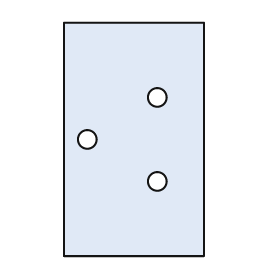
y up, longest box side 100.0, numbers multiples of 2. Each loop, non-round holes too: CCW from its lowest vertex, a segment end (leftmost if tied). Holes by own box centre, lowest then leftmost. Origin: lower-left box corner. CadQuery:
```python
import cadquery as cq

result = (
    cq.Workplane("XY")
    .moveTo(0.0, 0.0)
    .lineTo(60.0, 0.0)
    .lineTo(60.0, 100.0)
    .lineTo(0.0, 100.0)
    .close()
    .moveTo(40.0, 32.0)
    .circle(4.0)
    .moveTo(10.0, 50.0)
    .circle(4.0)
    .moveTo(40.0, 68.0)
    .circle(4.0)
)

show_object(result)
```